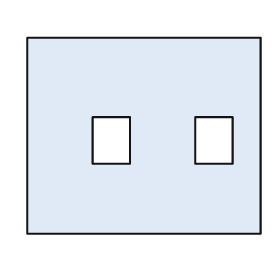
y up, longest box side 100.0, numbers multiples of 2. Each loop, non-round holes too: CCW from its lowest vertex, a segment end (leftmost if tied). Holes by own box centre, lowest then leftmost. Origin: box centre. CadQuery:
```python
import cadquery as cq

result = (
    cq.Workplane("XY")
    .moveTo(-50.0, -42.0)
    .lineTo(50.0, -42.0)
    .lineTo(50.0, 42.0)
    .lineTo(-50.0, 42.0)
    .close()
    .moveTo(-22.0, -12.0)
    .lineTo(-6.0, -12.0)
    .lineTo(-6.0, 8.0)
    .lineTo(-22.0, 8.0)
    .close()
    .moveTo(22.0, -12.0)
    .lineTo(38.0, -12.0)
    .lineTo(38.0, 8.0)
    .lineTo(22.0, 8.0)
    .close()
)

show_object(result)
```